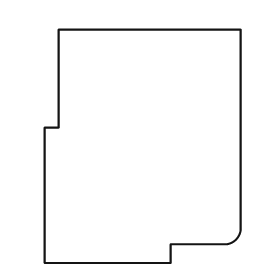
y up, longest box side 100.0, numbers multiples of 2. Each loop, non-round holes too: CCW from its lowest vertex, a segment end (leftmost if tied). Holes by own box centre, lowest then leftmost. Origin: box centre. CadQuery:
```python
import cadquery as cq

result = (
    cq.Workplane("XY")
    .moveTo(-42.0, -50.0)
    .lineTo(12.0, -50.0)
    .lineTo(12.0, -42.0)
    .lineTo(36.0, -42.0)
    .threePointArc((40.0, -40.0), (42.0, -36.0))
    .lineTo(42.0, 50.0)
    .lineTo(-36.0, 50.0)
    .lineTo(-36.0, 8.0)
    .lineTo(-42.0, 8.0)
    .close()
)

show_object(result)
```